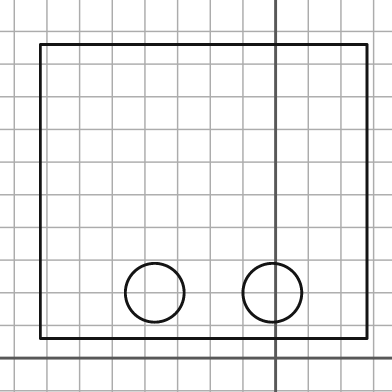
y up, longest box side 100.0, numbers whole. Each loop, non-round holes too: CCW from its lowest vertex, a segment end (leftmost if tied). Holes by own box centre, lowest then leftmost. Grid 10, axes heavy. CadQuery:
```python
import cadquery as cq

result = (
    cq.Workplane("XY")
    .moveTo(-72.0, 6.0)
    .lineTo(28.0, 6.0)
    .lineTo(28.0, 96.0)
    .lineTo(-72.0, 96.0)
    .close()
    .moveTo(-37.0, 20.0)
    .circle(9.0)
    .moveTo(-1.0, 20.0)
    .circle(9.0)
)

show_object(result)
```